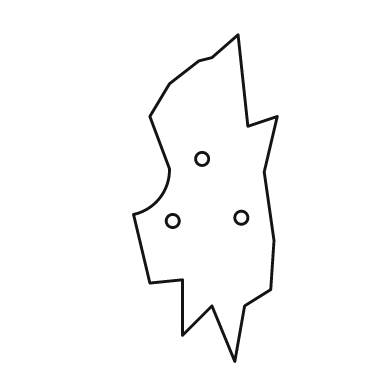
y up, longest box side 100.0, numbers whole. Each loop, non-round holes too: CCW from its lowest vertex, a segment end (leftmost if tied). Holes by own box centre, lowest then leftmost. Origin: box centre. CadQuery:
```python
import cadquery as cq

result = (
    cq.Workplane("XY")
    .moveTo(9.0, -50.0)
    .lineTo(12.0, -33.0)
    .lineTo(20.0, -28.0)
    .lineTo(21.0, -13.0)
    .lineTo(18.0, 8.0)
    .lineTo(22.0, 25.0)
    .lineTo(13.0, 22.0)
    .lineTo(10.0, 50.0)
    .lineTo(2.0, 43.0)
    .lineTo(-2.0, 42.0)
    .lineTo(-11.0, 35.0)
    .lineTo(-17.0, 25.0)
    .lineTo(-11.0, 9.0)
    .threePointArc((-14.0, 0.0), (-22.0, -5.0))
    .lineTo(-17.0, -26.0)
    .lineTo(-7.0, -25.0)
    .lineTo(-7.0, -42.0)
    .lineTo(2.0, -33.0)
    .close()
    .moveTo(-10.0, -7.0)
    .circle(2.0)
    .moveTo(11.0, -6.0)
    .circle(2.0)
    .moveTo(-1.0, 12.0)
    .circle(2.0)
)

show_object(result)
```